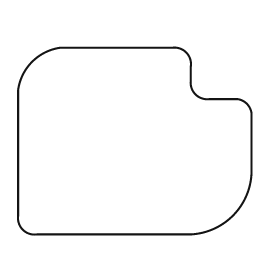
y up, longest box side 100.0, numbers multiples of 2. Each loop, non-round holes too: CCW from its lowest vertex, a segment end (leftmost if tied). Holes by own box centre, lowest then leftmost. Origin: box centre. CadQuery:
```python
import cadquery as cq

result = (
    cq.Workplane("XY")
    .moveTo(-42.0, -40.0)
    .lineTo(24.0, -40.0)
    .threePointArc((42.0, -32.0), (50.0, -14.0))
    .lineTo(50.0, 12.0)
    .threePointArc((48.0, 16.0), (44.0, 18.0))
    .lineTo(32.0, 18.0)
    .threePointArc((26.0, 20.0), (24.0, 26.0))
    .lineTo(24.0, 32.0)
    .threePointArc((22.0, 38.0), (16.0, 40.0))
    .lineTo(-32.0, 40.0)
    .threePointArc((-44.0, 34.0), (-50.0, 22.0))
    .lineTo(-50.0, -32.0)
    .threePointArc((-48.0, -38.0), (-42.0, -40.0))
    .close()
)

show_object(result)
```